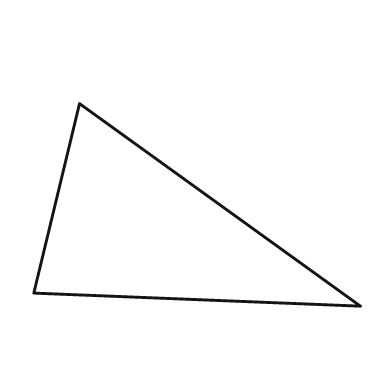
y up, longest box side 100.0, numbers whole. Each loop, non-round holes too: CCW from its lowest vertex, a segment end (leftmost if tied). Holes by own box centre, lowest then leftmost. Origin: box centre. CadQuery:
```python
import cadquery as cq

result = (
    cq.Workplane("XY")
    .moveTo(50.0, -31.0)
    .lineTo(-36.0, 31.0)
    .lineTo(-50.0, -27.0)
    .close()
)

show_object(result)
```